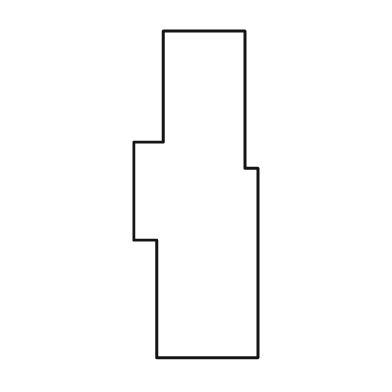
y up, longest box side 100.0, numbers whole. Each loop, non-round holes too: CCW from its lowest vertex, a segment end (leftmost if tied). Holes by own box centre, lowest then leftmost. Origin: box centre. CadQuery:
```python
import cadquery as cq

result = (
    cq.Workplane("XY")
    .moveTo(-12.0, -50.0)
    .lineTo(19.0, -50.0)
    .lineTo(19.0, 8.0)
    .lineTo(15.0, 8.0)
    .lineTo(15.0, 50.0)
    .lineTo(-10.0, 50.0)
    .lineTo(-10.0, 16.0)
    .lineTo(-19.0, 16.0)
    .lineTo(-19.0, -14.0)
    .lineTo(-12.0, -14.0)
    .close()
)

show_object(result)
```